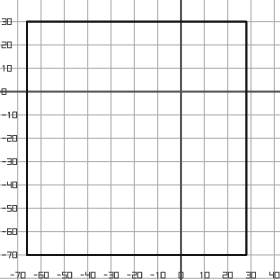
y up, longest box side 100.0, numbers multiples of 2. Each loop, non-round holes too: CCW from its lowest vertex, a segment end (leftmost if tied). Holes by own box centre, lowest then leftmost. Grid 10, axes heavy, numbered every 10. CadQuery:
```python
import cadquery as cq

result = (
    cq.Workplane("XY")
    .moveTo(-66.0, -70.0)
    .lineTo(28.0, -70.0)
    .lineTo(28.0, 30.0)
    .lineTo(-66.0, 30.0)
    .close()
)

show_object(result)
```